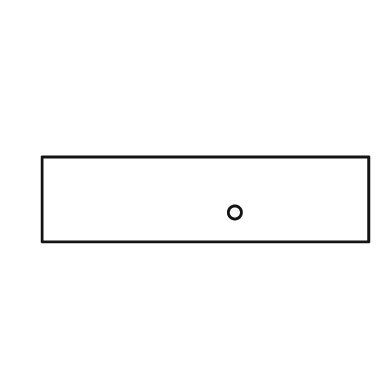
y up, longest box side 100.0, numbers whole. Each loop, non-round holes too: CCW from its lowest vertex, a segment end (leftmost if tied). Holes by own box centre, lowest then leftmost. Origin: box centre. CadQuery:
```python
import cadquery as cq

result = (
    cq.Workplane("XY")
    .moveTo(-50.0, -13.0)
    .lineTo(50.0, -13.0)
    .lineTo(50.0, 13.0)
    .lineTo(-50.0, 13.0)
    .close()
    .moveTo(9.0, -4.0)
    .circle(2.0)
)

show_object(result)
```